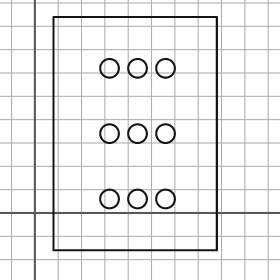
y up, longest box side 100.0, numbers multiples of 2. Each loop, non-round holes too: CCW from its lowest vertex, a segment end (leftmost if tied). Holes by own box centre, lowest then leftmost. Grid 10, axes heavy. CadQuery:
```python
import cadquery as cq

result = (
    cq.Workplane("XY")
    .moveTo(8.0, -16.0)
    .lineTo(78.0, -16.0)
    .lineTo(78.0, 84.0)
    .lineTo(8.0, 84.0)
    .close()
    .moveTo(32.0, 6.0)
    .circle(4.0)
    .moveTo(44.0, 6.0)
    .circle(4.0)
    .moveTo(56.0, 6.0)
    .circle(4.0)
    .moveTo(32.0, 34.0)
    .circle(4.0)
    .moveTo(44.0, 34.0)
    .circle(4.0)
    .moveTo(56.0, 34.0)
    .circle(4.0)
    .moveTo(32.0, 62.0)
    .circle(4.0)
    .moveTo(44.0, 62.0)
    .circle(4.0)
    .moveTo(56.0, 62.0)
    .circle(4.0)
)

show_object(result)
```